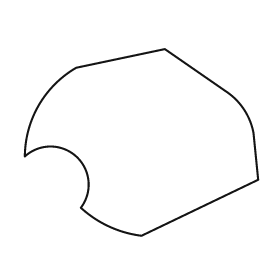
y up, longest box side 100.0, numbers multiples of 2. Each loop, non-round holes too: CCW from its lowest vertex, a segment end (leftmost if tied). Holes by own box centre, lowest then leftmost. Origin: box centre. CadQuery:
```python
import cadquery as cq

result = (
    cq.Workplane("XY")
    .moveTo(0.0, -40.0)
    .lineTo(50.0, -16.0)
    .lineTo(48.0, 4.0)
    .threePointArc((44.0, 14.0), (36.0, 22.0))
    .lineTo(10.0, 40.0)
    .lineTo(-28.0, 32.0)
    .threePointArc((-44.0, 16.0), (-50.0, -6.0))
    .threePointArc((-28.0, -6.0), (-26.0, -28.0))
    .threePointArc((-14.0, -36.0), (0.0, -40.0))
    .close()
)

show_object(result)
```